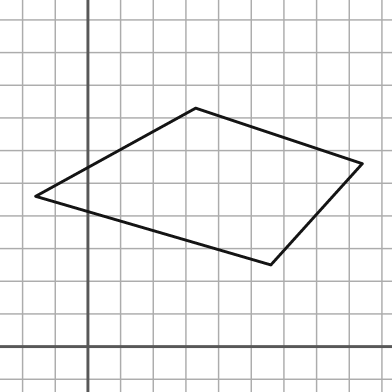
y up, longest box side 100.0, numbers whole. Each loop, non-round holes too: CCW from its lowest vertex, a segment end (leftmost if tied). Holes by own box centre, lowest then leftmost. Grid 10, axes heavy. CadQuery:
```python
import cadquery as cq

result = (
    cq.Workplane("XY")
    .moveTo(56.0, 25.0)
    .lineTo(84.0, 56.0)
    .lineTo(33.0, 73.0)
    .lineTo(-16.0, 46.0)
    .close()
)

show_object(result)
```